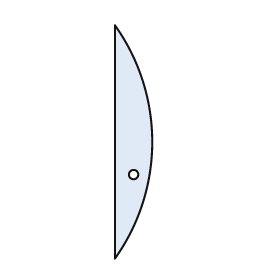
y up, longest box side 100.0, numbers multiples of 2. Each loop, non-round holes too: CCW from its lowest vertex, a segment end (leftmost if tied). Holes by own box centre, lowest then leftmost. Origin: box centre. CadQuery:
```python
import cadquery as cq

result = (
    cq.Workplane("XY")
    .moveTo(-8.0, -50.0)
    .threePointArc((8.0, 0.0), (-8.0, 50.0))
    .close()
    .moveTo(0.0, -14.0)
    .circle(2.0)
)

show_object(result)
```